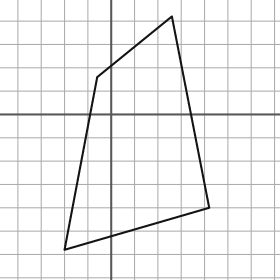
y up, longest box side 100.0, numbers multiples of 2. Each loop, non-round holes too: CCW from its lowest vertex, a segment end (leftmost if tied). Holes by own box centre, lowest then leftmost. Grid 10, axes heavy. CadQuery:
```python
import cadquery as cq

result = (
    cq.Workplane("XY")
    .moveTo(-20.0, -58.0)
    .lineTo(42.0, -40.0)
    .lineTo(26.0, 42.0)
    .lineTo(-6.0, 16.0)
    .close()
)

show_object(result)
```